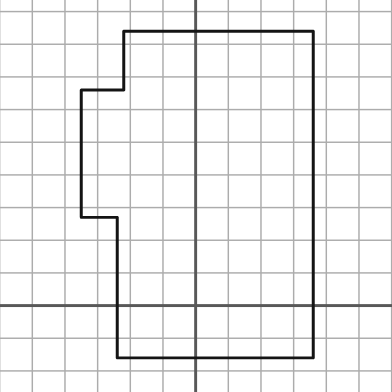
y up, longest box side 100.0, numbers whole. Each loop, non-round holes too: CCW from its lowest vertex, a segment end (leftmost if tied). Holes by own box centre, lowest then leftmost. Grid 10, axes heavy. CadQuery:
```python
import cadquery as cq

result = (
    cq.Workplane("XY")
    .moveTo(-24.0, -16.0)
    .lineTo(36.0, -16.0)
    .lineTo(36.0, 84.0)
    .lineTo(-22.0, 84.0)
    .lineTo(-22.0, 66.0)
    .lineTo(-35.0, 66.0)
    .lineTo(-35.0, 27.0)
    .lineTo(-24.0, 27.0)
    .close()
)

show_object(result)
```